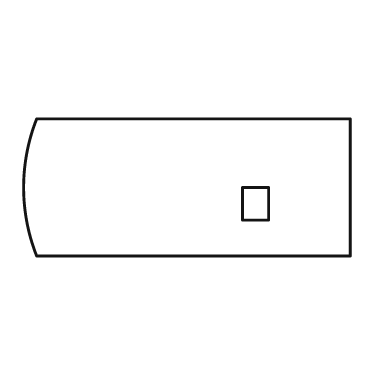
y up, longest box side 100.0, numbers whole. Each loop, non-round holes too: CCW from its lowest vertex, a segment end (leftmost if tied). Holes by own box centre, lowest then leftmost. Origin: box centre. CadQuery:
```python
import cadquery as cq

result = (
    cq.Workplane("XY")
    .moveTo(-46.0, -21.0)
    .lineTo(50.0, -21.0)
    .lineTo(50.0, 21.0)
    .lineTo(-46.0, 21.0)
    .threePointArc((-50.0, 0.0), (-46.0, -21.0))
    .close()
    .moveTo(17.0, -10.0)
    .lineTo(25.0, -10.0)
    .lineTo(25.0, 0.0)
    .lineTo(17.0, 0.0)
    .close()
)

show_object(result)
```